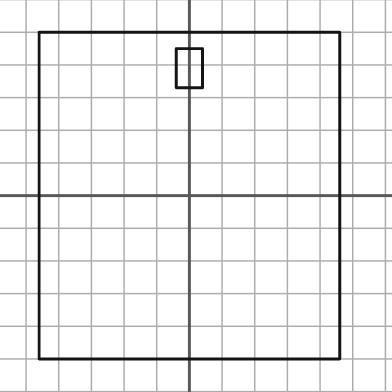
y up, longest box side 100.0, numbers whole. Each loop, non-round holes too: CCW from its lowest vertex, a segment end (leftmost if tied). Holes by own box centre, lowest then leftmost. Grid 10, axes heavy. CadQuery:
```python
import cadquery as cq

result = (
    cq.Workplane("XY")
    .moveTo(-46.0, -50.0)
    .lineTo(46.0, -50.0)
    .lineTo(46.0, 50.0)
    .lineTo(-46.0, 50.0)
    .close()
    .moveTo(-4.0, 33.0)
    .lineTo(4.0, 33.0)
    .lineTo(4.0, 45.0)
    .lineTo(-4.0, 45.0)
    .close()
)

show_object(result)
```